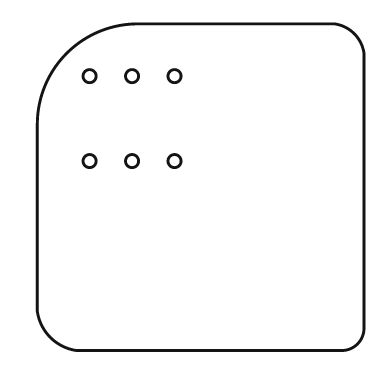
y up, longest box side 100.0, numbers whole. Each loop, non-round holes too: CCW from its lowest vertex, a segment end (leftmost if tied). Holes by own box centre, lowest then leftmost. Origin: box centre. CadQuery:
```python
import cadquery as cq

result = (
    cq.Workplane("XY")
    .moveTo(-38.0, -50.0)
    .lineTo(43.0, -50.0)
    .threePointArc((48.0, -48.0), (50.0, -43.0))
    .lineTo(50.0, 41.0)
    .threePointArc((47.0, 47.0), (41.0, 50.0))
    .lineTo(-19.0, 50.0)
    .threePointArc((-41.0, 41.0), (-50.0, 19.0))
    .lineTo(-50.0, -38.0)
    .threePointArc((-46.0, -46.0), (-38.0, -50.0))
    .close()
    .moveTo(-34.0, 8.0)
    .circle(2.0)
    .moveTo(-21.0, 8.0)
    .circle(2.0)
    .moveTo(-8.0, 8.0)
    .circle(2.0)
    .moveTo(-34.0, 34.0)
    .circle(2.0)
    .moveTo(-21.0, 34.0)
    .circle(2.0)
    .moveTo(-8.0, 34.0)
    .circle(2.0)
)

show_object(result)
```